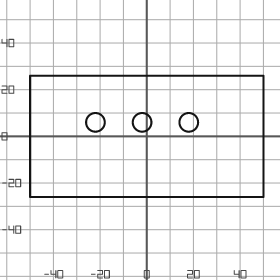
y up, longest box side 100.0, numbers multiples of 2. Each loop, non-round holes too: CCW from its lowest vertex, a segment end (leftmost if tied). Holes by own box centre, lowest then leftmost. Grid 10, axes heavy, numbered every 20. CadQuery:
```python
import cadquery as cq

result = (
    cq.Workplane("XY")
    .moveTo(-50.0, -26.0)
    .lineTo(50.0, -26.0)
    .lineTo(50.0, 26.0)
    .lineTo(-50.0, 26.0)
    .close()
    .moveTo(-22.0, 6.0)
    .circle(4.0)
    .moveTo(-2.0, 6.0)
    .circle(4.0)
    .moveTo(18.0, 6.0)
    .circle(4.0)
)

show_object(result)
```